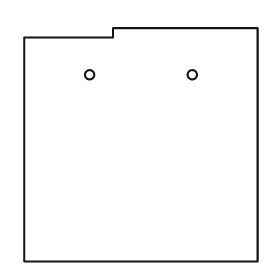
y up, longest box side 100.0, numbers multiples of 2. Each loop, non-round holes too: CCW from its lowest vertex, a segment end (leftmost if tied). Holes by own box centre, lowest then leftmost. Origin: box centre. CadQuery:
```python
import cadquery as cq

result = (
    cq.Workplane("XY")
    .moveTo(-50.0, -50.0)
    .lineTo(50.0, -50.0)
    .lineTo(50.0, 50.0)
    .lineTo(-12.0, 50.0)
    .lineTo(-12.0, 46.0)
    .lineTo(-50.0, 46.0)
    .close()
    .moveTo(-22.0, 30.0)
    .circle(2.0)
    .moveTo(22.0, 30.0)
    .circle(2.0)
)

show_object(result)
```